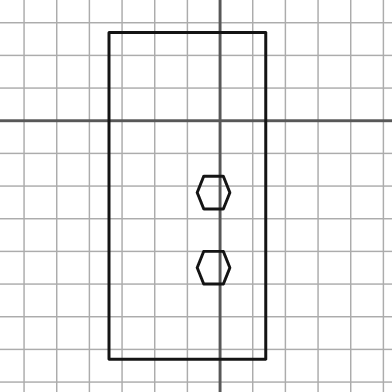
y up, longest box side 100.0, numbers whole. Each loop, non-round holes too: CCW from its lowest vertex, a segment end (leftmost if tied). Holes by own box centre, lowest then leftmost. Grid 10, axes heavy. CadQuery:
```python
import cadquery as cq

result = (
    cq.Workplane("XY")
    .moveTo(-34.0, -73.0)
    .lineTo(14.0, -73.0)
    .lineTo(14.0, 27.0)
    .lineTo(-34.0, 27.0)
    .close()
    .moveTo(-5.0, -50.0)
    .lineTo(1.0, -50.0)
    .lineTo(3.0, -45.0)
    .lineTo(1.0, -40.0)
    .lineTo(-5.0, -40.0)
    .lineTo(-7.0, -45.0)
    .close()
    .moveTo(-5.0, -27.0)
    .lineTo(1.0, -27.0)
    .lineTo(3.0, -22.0)
    .lineTo(1.0, -17.0)
    .lineTo(-5.0, -17.0)
    .lineTo(-7.0, -22.0)
    .close()
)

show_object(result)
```